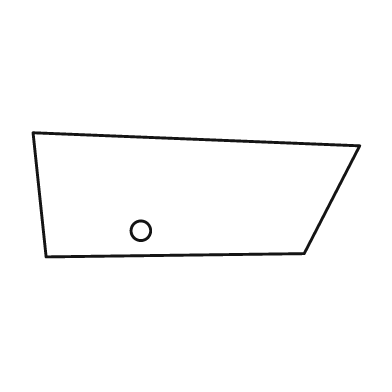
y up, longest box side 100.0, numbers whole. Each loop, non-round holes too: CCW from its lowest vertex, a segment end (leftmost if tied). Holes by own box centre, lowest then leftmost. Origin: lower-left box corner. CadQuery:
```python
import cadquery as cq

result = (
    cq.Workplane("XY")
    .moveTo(4.0, 0.0)
    .lineTo(83.0, 1.0)
    .lineTo(100.0, 34.0)
    .lineTo(0.0, 38.0)
    .close()
    .moveTo(33.0, 8.0)
    .circle(3.0)
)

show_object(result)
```